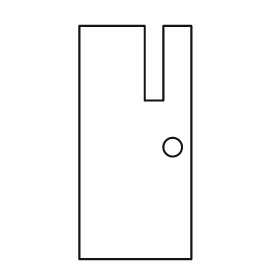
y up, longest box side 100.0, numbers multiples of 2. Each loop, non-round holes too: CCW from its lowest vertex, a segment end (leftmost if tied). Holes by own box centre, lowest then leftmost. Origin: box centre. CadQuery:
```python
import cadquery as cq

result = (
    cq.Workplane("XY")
    .moveTo(-24.0, -50.0)
    .lineTo(24.0, -50.0)
    .lineTo(24.0, 50.0)
    .lineTo(12.0, 50.0)
    .lineTo(12.0, 18.0)
    .lineTo(4.0, 18.0)
    .lineTo(4.0, 50.0)
    .lineTo(-24.0, 50.0)
    .close()
    .moveTo(16.0, -2.0)
    .circle(4.0)
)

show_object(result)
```